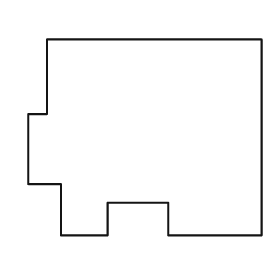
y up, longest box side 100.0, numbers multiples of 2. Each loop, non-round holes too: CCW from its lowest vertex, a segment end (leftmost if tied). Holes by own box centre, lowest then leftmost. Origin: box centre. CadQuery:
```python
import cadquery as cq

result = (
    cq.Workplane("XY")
    .moveTo(-36.0, -42.0)
    .lineTo(-16.0, -42.0)
    .lineTo(-16.0, -28.0)
    .lineTo(10.0, -28.0)
    .lineTo(10.0, -42.0)
    .lineTo(50.0, -42.0)
    .lineTo(50.0, 42.0)
    .lineTo(-42.0, 42.0)
    .lineTo(-42.0, 10.0)
    .lineTo(-50.0, 10.0)
    .lineTo(-50.0, -20.0)
    .lineTo(-36.0, -20.0)
    .close()
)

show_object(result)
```